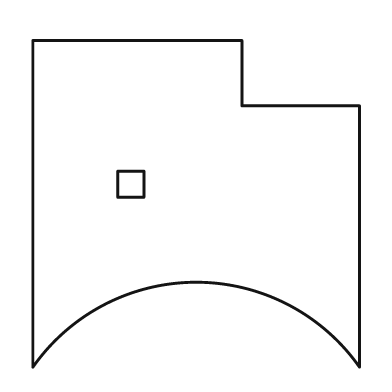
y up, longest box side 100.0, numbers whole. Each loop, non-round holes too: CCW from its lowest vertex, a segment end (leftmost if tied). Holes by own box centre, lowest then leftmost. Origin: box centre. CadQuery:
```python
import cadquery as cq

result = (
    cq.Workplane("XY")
    .moveTo(-50.0, -50.0)
    .threePointArc((0.0, -24.0), (50.0, -50.0))
    .lineTo(50.0, 30.0)
    .lineTo(14.0, 30.0)
    .lineTo(14.0, 50.0)
    .lineTo(-50.0, 50.0)
    .close()
    .moveTo(-24.0, 2.0)
    .lineTo(-16.0, 2.0)
    .lineTo(-16.0, 10.0)
    .lineTo(-24.0, 10.0)
    .close()
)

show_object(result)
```